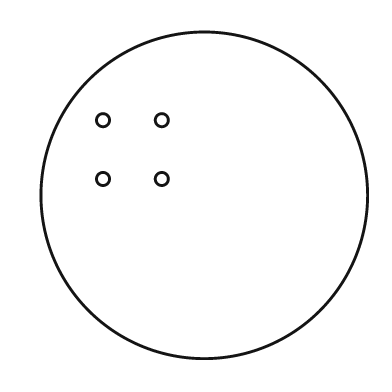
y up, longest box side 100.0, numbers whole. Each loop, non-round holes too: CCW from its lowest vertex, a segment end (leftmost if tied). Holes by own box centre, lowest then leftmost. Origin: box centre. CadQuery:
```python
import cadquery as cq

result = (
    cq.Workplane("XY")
    .moveTo(0.0, 0.0)
    .circle(50.0)
    .moveTo(-31.0, 5.0)
    .circle(2.0)
    .moveTo(-13.0, 5.0)
    .circle(2.0)
    .moveTo(-31.0, 23.0)
    .circle(2.0)
    .moveTo(-13.0, 23.0)
    .circle(2.0)
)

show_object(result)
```